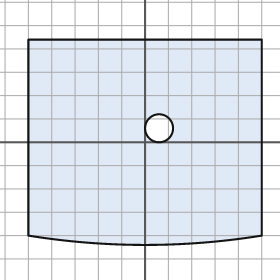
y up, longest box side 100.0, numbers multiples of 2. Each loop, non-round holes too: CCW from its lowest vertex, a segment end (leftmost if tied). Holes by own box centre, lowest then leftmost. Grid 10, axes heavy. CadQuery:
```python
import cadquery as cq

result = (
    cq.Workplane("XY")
    .moveTo(-50.0, -40.0)
    .threePointArc((0.0, -44.0), (50.0, -40.0))
    .lineTo(50.0, 44.0)
    .lineTo(-50.0, 44.0)
    .close()
    .moveTo(6.0, 6.0)
    .circle(6.0)
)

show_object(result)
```